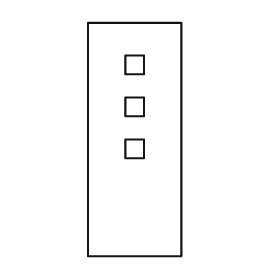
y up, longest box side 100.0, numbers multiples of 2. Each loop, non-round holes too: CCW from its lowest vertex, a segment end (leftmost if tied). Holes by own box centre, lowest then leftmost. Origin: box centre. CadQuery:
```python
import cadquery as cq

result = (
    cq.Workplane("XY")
    .moveTo(-20.0, -50.0)
    .lineTo(20.0, -50.0)
    .lineTo(20.0, 50.0)
    .lineTo(-20.0, 50.0)
    .close()
    .moveTo(-4.0, -8.0)
    .lineTo(4.0, -8.0)
    .lineTo(4.0, 0.0)
    .lineTo(-4.0, 0.0)
    .close()
    .moveTo(-4.0, 10.0)
    .lineTo(4.0, 10.0)
    .lineTo(4.0, 18.0)
    .lineTo(-4.0, 18.0)
    .close()
    .moveTo(-4.0, 28.0)
    .lineTo(4.0, 28.0)
    .lineTo(4.0, 36.0)
    .lineTo(-4.0, 36.0)
    .close()
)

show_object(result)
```